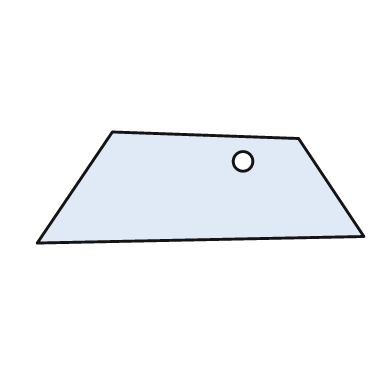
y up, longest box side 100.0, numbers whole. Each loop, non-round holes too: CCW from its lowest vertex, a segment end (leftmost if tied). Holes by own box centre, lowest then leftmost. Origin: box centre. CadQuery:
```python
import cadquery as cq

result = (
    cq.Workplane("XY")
    .moveTo(-50.0, -17.0)
    .lineTo(50.0, -15.0)
    .lineTo(30.0, 15.0)
    .lineTo(-27.0, 17.0)
    .close()
    .moveTo(13.0, 8.0)
    .circle(3.0)
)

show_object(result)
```